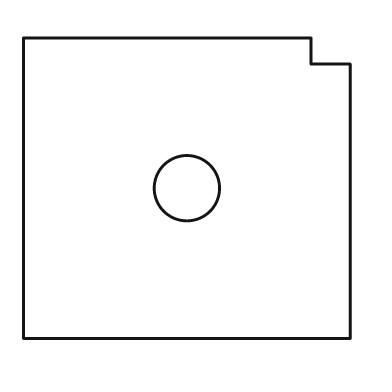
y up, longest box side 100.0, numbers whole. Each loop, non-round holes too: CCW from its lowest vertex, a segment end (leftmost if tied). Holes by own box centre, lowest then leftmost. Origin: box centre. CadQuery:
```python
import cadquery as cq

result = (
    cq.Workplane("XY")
    .moveTo(-50.0, -46.0)
    .lineTo(50.0, -46.0)
    .lineTo(50.0, 38.0)
    .lineTo(38.0, 38.0)
    .lineTo(38.0, 46.0)
    .lineTo(-50.0, 46.0)
    .close()
    .moveTo(0.0, 0.0)
    .circle(10.0)
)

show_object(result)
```